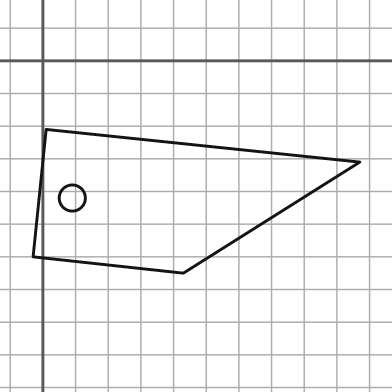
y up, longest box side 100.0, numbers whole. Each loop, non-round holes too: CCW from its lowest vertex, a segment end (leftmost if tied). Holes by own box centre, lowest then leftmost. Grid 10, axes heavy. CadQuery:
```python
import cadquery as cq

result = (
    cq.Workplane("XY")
    .moveTo(43.0, -65.0)
    .lineTo(97.0, -31.0)
    .lineTo(1.0, -21.0)
    .lineTo(-3.0, -60.0)
    .close()
    .moveTo(9.0, -42.0)
    .circle(4.0)
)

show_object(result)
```